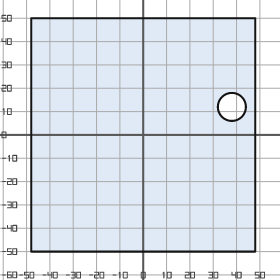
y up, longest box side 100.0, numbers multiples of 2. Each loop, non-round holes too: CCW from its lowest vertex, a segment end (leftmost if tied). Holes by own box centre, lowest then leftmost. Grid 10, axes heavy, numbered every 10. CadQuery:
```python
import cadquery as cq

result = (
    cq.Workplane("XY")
    .moveTo(-48.0, -50.0)
    .lineTo(48.0, -50.0)
    .lineTo(48.0, 50.0)
    .lineTo(-48.0, 50.0)
    .close()
    .moveTo(38.0, 12.0)
    .circle(6.0)
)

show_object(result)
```